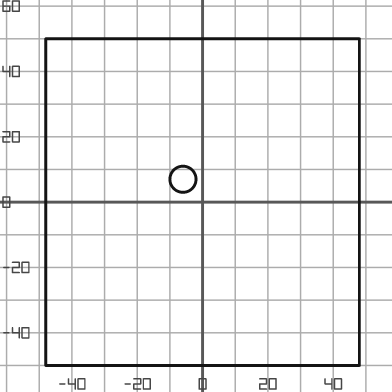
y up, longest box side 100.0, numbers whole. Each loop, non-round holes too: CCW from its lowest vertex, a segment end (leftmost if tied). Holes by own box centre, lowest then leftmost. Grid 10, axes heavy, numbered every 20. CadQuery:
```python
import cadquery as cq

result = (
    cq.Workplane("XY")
    .moveTo(-48.0, -50.0)
    .lineTo(48.0, -50.0)
    .lineTo(48.0, 50.0)
    .lineTo(-48.0, 50.0)
    .close()
    .moveTo(-6.0, 7.0)
    .circle(4.0)
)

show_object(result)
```